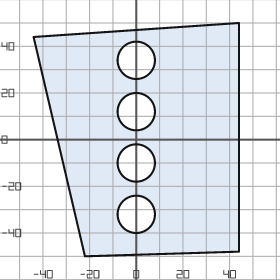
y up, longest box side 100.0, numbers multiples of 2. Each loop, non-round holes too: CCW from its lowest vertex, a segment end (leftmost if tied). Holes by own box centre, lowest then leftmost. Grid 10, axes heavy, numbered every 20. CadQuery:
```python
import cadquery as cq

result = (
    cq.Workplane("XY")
    .moveTo(-22.0, -50.0)
    .lineTo(44.0, -48.0)
    .lineTo(44.0, 50.0)
    .lineTo(-44.0, 44.0)
    .close()
    .moveTo(0.0, -32.0)
    .circle(8.0)
    .moveTo(0.0, -10.0)
    .circle(8.0)
    .moveTo(0.0, 12.0)
    .circle(8.0)
    .moveTo(0.0, 34.0)
    .circle(8.0)
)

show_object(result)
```